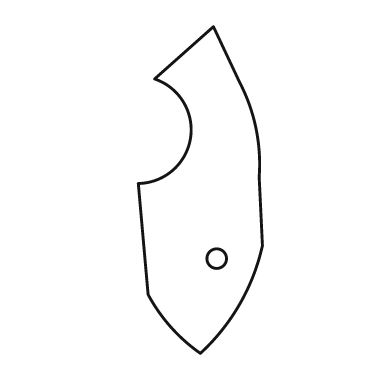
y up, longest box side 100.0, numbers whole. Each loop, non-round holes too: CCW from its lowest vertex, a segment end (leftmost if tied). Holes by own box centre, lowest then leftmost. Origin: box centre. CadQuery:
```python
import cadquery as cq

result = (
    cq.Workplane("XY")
    .moveTo(0.0, -50.0)
    .threePointArc((12.0, -35.0), (19.0, -17.0))
    .lineTo(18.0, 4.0)
    .threePointArc((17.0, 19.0), (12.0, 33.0))
    .lineTo(4.0, 50.0)
    .lineTo(-14.0, 34.0)
    .threePointArc((-3.0, 16.0), (-19.0, 2.0))
    .lineTo(-16.0, -32.0)
    .threePointArc((-9.0, -42.0), (0.0, -50.0))
    .close()
    .moveTo(5.0, -21.0)
    .circle(3.0)
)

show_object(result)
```